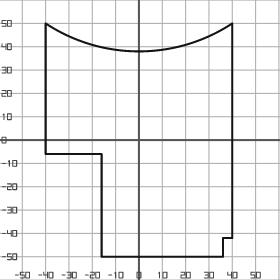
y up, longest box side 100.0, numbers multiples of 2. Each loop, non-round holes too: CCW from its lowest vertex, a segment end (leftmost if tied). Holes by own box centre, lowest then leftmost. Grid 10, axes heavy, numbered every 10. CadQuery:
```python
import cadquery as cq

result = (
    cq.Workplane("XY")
    .moveTo(-16.0, -50.0)
    .lineTo(36.0, -50.0)
    .lineTo(36.0, -42.0)
    .lineTo(40.0, -42.0)
    .lineTo(40.0, 50.0)
    .threePointArc((0.0, 38.0), (-40.0, 50.0))
    .lineTo(-40.0, -6.0)
    .lineTo(-16.0, -6.0)
    .close()
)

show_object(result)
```